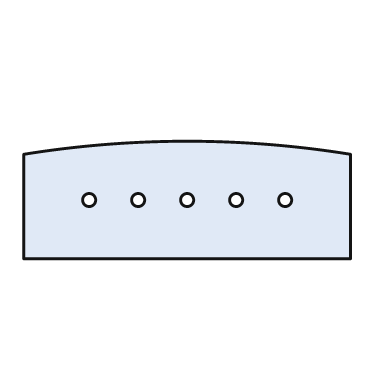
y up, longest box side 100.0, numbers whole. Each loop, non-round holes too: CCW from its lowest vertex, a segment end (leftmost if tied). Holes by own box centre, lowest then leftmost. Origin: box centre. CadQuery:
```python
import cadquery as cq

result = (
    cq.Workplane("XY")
    .moveTo(-50.0, -18.0)
    .lineTo(50.0, -18.0)
    .lineTo(50.0, 14.0)
    .threePointArc((0.0, 18.0), (-50.0, 14.0))
    .close()
    .moveTo(-30.0, 0.0)
    .circle(2.0)
    .moveTo(-15.0, 0.0)
    .circle(2.0)
    .moveTo(0.0, 0.0)
    .circle(2.0)
    .moveTo(15.0, 0.0)
    .circle(2.0)
    .moveTo(30.0, 0.0)
    .circle(2.0)
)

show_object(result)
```